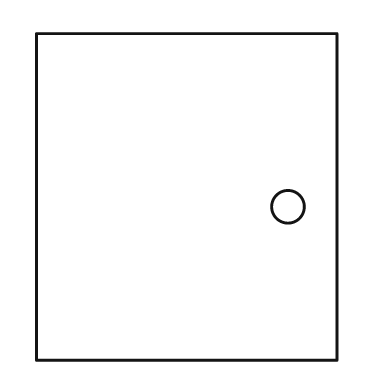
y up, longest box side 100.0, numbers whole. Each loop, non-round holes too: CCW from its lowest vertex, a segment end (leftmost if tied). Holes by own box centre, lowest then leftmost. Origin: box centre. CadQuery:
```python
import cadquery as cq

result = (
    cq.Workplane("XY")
    .moveTo(-46.0, -50.0)
    .lineTo(46.0, -50.0)
    .lineTo(46.0, 50.0)
    .lineTo(-46.0, 50.0)
    .close()
    .moveTo(31.0, -3.0)
    .circle(5.0)
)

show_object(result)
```